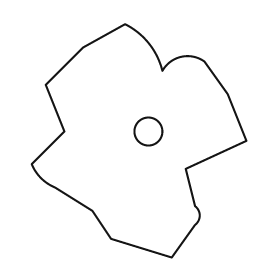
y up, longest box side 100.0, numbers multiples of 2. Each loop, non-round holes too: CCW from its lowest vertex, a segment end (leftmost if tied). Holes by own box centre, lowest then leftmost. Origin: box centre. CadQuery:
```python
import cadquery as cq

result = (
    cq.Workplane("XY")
    .moveTo(14.0, -50.0)
    .lineTo(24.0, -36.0)
    .threePointArc((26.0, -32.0), (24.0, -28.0))
    .lineTo(20.0, -12.0)
    .lineTo(46.0, 0.0)
    .lineTo(38.0, 20.0)
    .lineTo(28.0, 34.0)
    .threePointArc((18.0, 36.0), (10.0, 30.0))
    .threePointArc((4.0, 42.0), (-6.0, 50.0))
    .lineTo(-24.0, 40.0)
    .lineTo(-40.0, 24.0)
    .lineTo(-32.0, 4.0)
    .lineTo(-46.0, -10.0)
    .threePointArc((-42.0, -16.0), (-36.0, -20.0))
    .lineTo(-20.0, -30.0)
    .lineTo(-12.0, -42.0)
    .close()
    .moveTo(4.0, 4.0)
    .circle(6.0)
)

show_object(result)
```